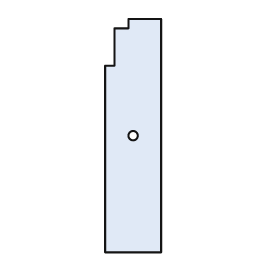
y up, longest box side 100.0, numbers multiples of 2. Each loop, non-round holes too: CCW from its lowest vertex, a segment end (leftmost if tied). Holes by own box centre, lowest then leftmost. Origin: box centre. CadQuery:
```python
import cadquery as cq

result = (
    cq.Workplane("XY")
    .moveTo(-12.0, -50.0)
    .lineTo(12.0, -50.0)
    .lineTo(12.0, 50.0)
    .lineTo(-2.0, 50.0)
    .lineTo(-2.0, 46.0)
    .lineTo(-8.0, 46.0)
    .lineTo(-8.0, 30.0)
    .lineTo(-12.0, 30.0)
    .close()
    .moveTo(0.0, 0.0)
    .circle(2.0)
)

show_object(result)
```